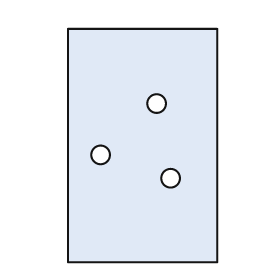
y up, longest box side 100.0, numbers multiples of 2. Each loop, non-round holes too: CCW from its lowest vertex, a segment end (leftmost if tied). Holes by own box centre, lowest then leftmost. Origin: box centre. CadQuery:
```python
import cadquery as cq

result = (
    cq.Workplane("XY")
    .moveTo(-32.0, -50.0)
    .lineTo(32.0, -50.0)
    .lineTo(32.0, 50.0)
    .lineTo(-32.0, 50.0)
    .close()
    .moveTo(12.0, -14.0)
    .circle(4.0)
    .moveTo(-18.0, -4.0)
    .circle(4.0)
    .moveTo(6.0, 18.0)
    .circle(4.0)
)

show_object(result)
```